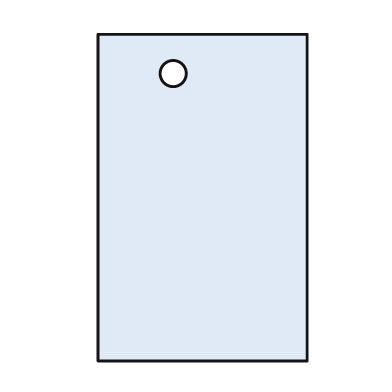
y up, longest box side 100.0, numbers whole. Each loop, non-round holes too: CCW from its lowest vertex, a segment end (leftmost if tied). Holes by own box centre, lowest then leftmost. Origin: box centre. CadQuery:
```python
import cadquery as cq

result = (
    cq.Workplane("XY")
    .moveTo(-32.0, -50.0)
    .lineTo(32.0, -50.0)
    .lineTo(32.0, 50.0)
    .lineTo(-32.0, 50.0)
    .close()
    .moveTo(-9.0, 38.0)
    .circle(4.0)
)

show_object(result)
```